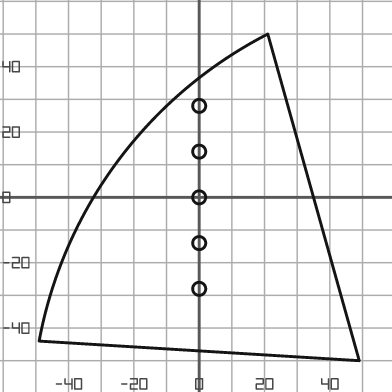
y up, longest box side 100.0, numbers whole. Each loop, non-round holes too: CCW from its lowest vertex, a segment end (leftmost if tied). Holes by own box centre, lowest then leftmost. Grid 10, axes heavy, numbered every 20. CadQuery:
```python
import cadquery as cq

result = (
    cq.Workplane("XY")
    .moveTo(49.0, -50.0)
    .lineTo(21.0, 50.0)
    .threePointArc((-25.0, 11.0), (-49.0, -44.0))
    .close()
    .moveTo(0.0, -28.0)
    .circle(2.0)
    .moveTo(0.0, -14.0)
    .circle(2.0)
    .moveTo(0.0, 0.0)
    .circle(2.0)
    .moveTo(0.0, 14.0)
    .circle(2.0)
    .moveTo(0.0, 28.0)
    .circle(2.0)
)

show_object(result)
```